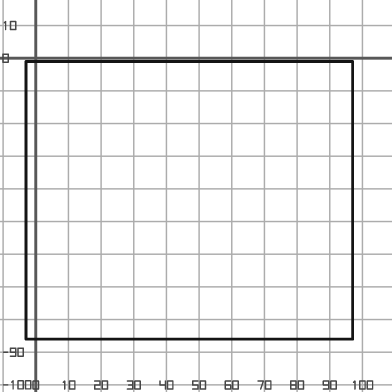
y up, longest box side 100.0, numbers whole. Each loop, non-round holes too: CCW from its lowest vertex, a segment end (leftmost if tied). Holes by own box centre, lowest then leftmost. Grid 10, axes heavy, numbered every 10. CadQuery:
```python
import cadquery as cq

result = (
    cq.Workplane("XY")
    .moveTo(-3.0, -86.0)
    .lineTo(97.0, -86.0)
    .lineTo(97.0, -1.0)
    .lineTo(-3.0, -1.0)
    .close()
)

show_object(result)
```